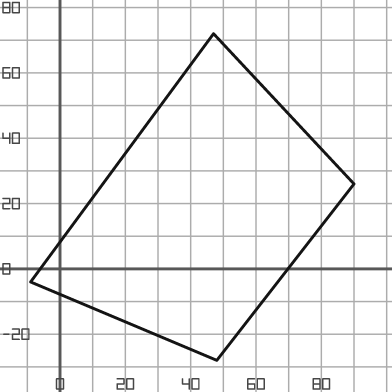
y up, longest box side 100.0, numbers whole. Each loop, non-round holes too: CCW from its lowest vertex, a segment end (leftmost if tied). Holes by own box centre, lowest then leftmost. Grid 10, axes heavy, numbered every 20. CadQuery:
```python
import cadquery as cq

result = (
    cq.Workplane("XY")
    .moveTo(48.0, -28.0)
    .lineTo(90.0, 26.0)
    .lineTo(47.0, 72.0)
    .lineTo(-9.0, -4.0)
    .close()
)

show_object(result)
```